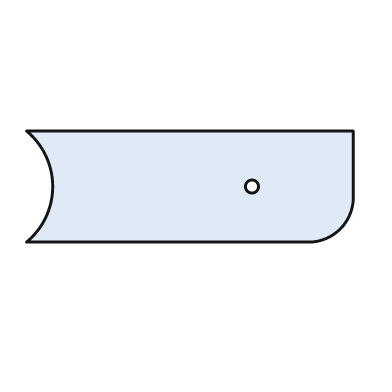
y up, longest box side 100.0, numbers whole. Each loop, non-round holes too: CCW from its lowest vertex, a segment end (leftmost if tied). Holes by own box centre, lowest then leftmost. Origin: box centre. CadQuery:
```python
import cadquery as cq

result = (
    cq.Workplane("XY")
    .moveTo(-50.0, -17.0)
    .lineTo(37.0, -17.0)
    .threePointArc((46.0, -13.0), (50.0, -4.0))
    .lineTo(50.0, 17.0)
    .lineTo(-50.0, 17.0)
    .threePointArc((-42.0, 0.0), (-50.0, -17.0))
    .close()
    .moveTo(19.0, 0.0)
    .circle(2.0)
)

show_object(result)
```